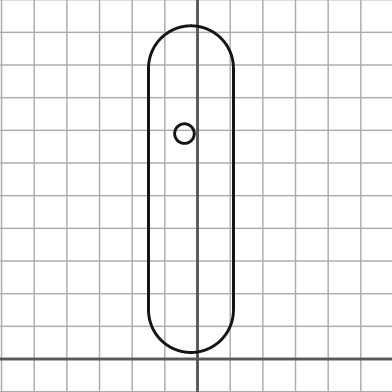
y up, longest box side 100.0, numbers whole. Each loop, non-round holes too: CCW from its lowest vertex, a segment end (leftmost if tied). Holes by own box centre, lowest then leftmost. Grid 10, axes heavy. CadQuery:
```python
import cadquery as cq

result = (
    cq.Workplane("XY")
    .moveTo(-15.0, 15.0)
    .threePointArc((-2.0, 2.0), (11.0, 15.0))
    .lineTo(11.0, 89.0)
    .threePointArc((-2.0, 102.0), (-15.0, 89.0))
    .close()
    .moveTo(-4.0, 69.0)
    .circle(3.0)
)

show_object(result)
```